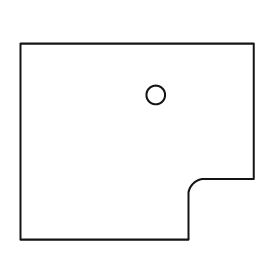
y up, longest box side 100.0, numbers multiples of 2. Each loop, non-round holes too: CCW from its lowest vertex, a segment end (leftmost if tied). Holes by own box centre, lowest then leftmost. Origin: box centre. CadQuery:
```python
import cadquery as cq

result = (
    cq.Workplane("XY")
    .moveTo(-50.0, -42.0)
    .lineTo(22.0, -42.0)
    .lineTo(22.0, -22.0)
    .threePointArc((24.0, -18.0), (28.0, -16.0))
    .lineTo(50.0, -16.0)
    .lineTo(50.0, 42.0)
    .lineTo(-50.0, 42.0)
    .close()
    .moveTo(8.0, 20.0)
    .circle(4.0)
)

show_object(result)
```